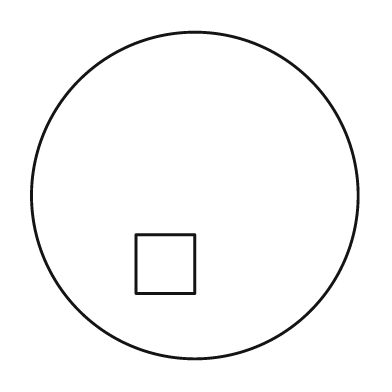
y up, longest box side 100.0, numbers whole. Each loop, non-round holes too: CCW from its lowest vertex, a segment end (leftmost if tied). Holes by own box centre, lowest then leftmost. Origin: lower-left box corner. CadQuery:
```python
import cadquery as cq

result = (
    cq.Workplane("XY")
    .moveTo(50.0, 50.0)
    .circle(50.0)
    .moveTo(32.0, 20.0)
    .lineTo(50.0, 20.0)
    .lineTo(50.0, 38.0)
    .lineTo(32.0, 38.0)
    .close()
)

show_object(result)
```